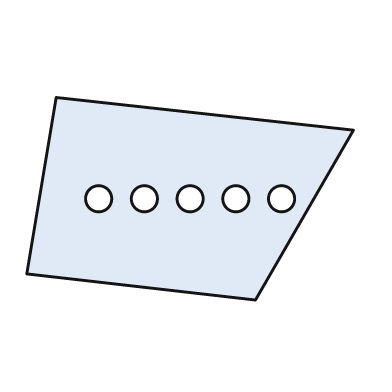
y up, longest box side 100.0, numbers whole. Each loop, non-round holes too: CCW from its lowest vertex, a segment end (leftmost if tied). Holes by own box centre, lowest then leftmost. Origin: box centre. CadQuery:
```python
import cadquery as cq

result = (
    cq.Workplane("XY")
    .moveTo(20.0, -31.0)
    .lineTo(50.0, 21.0)
    .lineTo(-41.0, 31.0)
    .lineTo(-50.0, -23.0)
    .close()
    .moveTo(-28.0, 0.0)
    .circle(4.0)
    .moveTo(-14.0, 0.0)
    .circle(4.0)
    .moveTo(0.0, 0.0)
    .circle(4.0)
    .moveTo(14.0, 0.0)
    .circle(4.0)
    .moveTo(28.0, 0.0)
    .circle(4.0)
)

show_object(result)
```